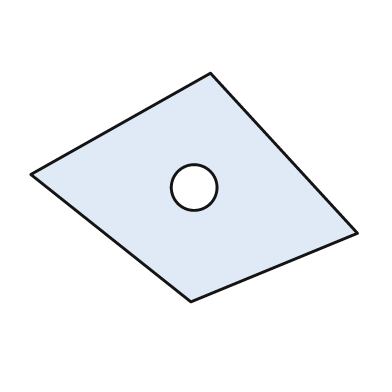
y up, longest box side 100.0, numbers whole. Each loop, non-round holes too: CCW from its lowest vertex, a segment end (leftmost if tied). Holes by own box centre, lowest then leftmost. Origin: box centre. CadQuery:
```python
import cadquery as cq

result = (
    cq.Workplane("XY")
    .moveTo(-1.0, -35.0)
    .lineTo(50.0, -14.0)
    .lineTo(5.0, 35.0)
    .lineTo(-50.0, 4.0)
    .close()
    .moveTo(0.0, 0.0)
    .circle(7.0)
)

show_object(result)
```